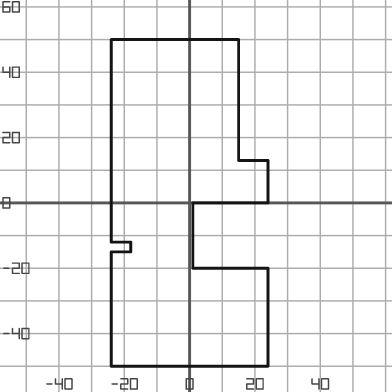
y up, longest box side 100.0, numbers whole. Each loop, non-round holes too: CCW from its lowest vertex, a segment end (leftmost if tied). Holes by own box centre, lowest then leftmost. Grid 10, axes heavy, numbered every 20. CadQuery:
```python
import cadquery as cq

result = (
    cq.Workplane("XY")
    .moveTo(-24.0, -50.0)
    .lineTo(24.0, -50.0)
    .lineTo(24.0, -20.0)
    .lineTo(1.0, -20.0)
    .lineTo(1.0, 0.0)
    .lineTo(24.0, 0.0)
    .lineTo(24.0, 13.0)
    .lineTo(15.0, 13.0)
    .lineTo(15.0, 50.0)
    .lineTo(-24.0, 50.0)
    .lineTo(-24.0, -12.0)
    .lineTo(-18.0, -12.0)
    .lineTo(-18.0, -15.0)
    .lineTo(-24.0, -15.0)
    .close()
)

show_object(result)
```